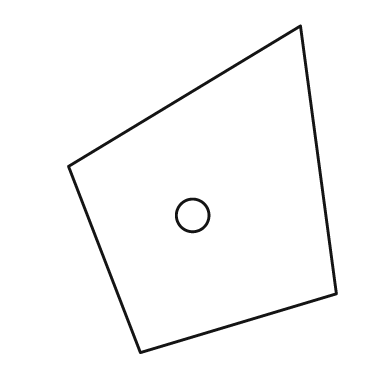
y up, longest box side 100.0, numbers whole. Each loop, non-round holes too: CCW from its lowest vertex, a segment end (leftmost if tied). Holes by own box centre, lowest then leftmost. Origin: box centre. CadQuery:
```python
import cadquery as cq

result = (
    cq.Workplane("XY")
    .moveTo(-19.0, -50.0)
    .lineTo(41.0, -32.0)
    .lineTo(30.0, 50.0)
    .lineTo(-41.0, 7.0)
    .close()
    .moveTo(-3.0, -8.0)
    .circle(5.0)
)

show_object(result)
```